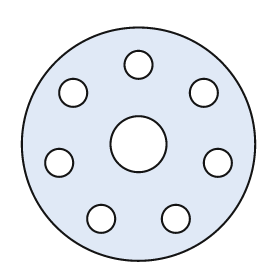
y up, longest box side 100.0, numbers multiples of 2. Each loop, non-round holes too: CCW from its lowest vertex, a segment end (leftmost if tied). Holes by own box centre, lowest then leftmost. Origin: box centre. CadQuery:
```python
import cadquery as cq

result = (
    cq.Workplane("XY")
    .moveTo(0.0, 0.0)
    .circle(50.0)
    .moveTo(-16.0, -32.0)
    .circle(6.0)
    .moveTo(16.0, -32.0)
    .circle(6.0)
    .moveTo(-34.0, -8.0)
    .circle(6.0)
    .moveTo(34.0, -8.0)
    .circle(6.0)
    .moveTo(0.0, 0.0)
    .circle(12.0)
    .moveTo(-28.0, 22.0)
    .circle(6.0)
    .moveTo(28.0, 22.0)
    .circle(6.0)
    .moveTo(0.0, 34.0)
    .circle(6.0)
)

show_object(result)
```